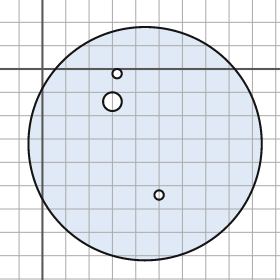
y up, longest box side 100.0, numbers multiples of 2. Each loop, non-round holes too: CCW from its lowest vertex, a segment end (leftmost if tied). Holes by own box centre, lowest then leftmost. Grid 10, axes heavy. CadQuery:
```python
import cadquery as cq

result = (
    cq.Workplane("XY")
    .moveTo(44.0, -32.0)
    .circle(50.0)
    .moveTo(50.0, -54.0)
    .circle(2.0)
    .moveTo(30.0, -14.0)
    .circle(4.0)
    .moveTo(32.0, -2.0)
    .circle(2.0)
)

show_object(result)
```